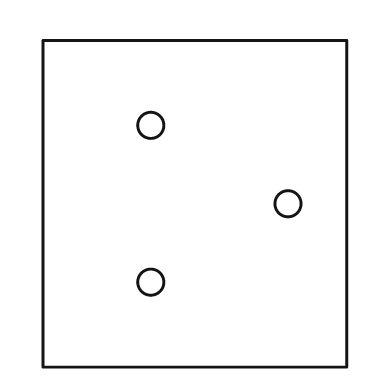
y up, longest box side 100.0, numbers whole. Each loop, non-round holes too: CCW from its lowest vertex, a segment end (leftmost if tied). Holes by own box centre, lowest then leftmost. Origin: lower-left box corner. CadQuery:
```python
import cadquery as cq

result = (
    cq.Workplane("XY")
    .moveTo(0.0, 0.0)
    .lineTo(93.0, 0.0)
    .lineTo(93.0, 100.0)
    .lineTo(0.0, 100.0)
    .close()
    .moveTo(33.0, 26.0)
    .circle(4.0)
    .moveTo(75.0, 50.0)
    .circle(4.0)
    .moveTo(33.0, 74.0)
    .circle(4.0)
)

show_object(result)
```